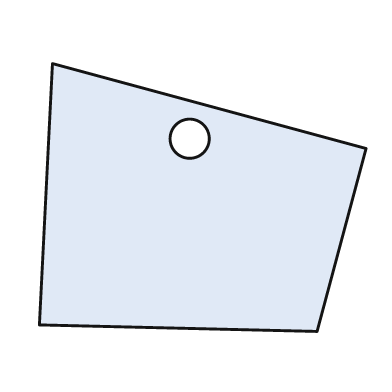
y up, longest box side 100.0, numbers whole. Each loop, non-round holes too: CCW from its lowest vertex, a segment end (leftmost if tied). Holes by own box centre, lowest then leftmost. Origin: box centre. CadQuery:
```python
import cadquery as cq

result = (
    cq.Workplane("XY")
    .moveTo(35.0, -41.0)
    .lineTo(50.0, 15.0)
    .lineTo(-46.0, 41.0)
    .lineTo(-50.0, -39.0)
    .close()
    .moveTo(-4.0, 18.0)
    .circle(6.0)
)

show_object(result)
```